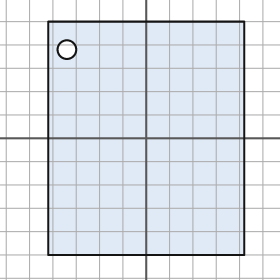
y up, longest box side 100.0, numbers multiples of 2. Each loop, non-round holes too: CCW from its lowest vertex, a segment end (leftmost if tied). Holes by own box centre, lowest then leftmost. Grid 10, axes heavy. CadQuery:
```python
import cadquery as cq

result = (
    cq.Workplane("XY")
    .moveTo(-42.0, -50.0)
    .lineTo(42.0, -50.0)
    .lineTo(42.0, 50.0)
    .lineTo(-42.0, 50.0)
    .close()
    .moveTo(-34.0, 38.0)
    .circle(4.0)
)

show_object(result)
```